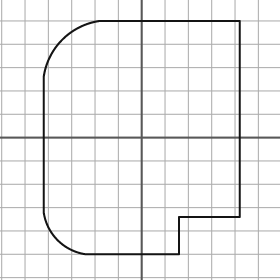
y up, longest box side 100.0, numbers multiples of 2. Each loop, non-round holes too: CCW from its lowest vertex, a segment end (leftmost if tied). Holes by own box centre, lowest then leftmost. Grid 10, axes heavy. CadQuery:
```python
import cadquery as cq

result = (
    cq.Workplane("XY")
    .moveTo(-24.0, -50.0)
    .lineTo(16.0, -50.0)
    .lineTo(16.0, -34.0)
    .lineTo(42.0, -34.0)
    .lineTo(42.0, 50.0)
    .lineTo(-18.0, 50.0)
    .threePointArc((-34.0, 42.0), (-42.0, 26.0))
    .lineTo(-42.0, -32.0)
    .threePointArc((-36.0, -44.0), (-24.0, -50.0))
    .close()
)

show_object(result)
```